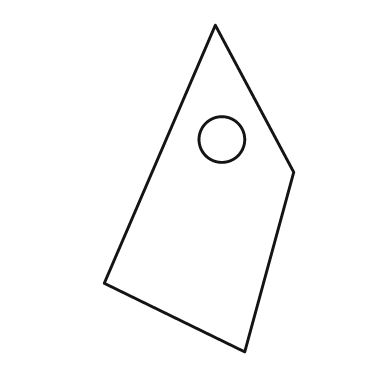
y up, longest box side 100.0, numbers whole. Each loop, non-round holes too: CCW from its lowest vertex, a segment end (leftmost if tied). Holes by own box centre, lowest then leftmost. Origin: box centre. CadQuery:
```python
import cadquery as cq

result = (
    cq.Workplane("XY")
    .moveTo(14.0, -50.0)
    .lineTo(29.0, 5.0)
    .lineTo(5.0, 50.0)
    .lineTo(-29.0, -29.0)
    .close()
    .moveTo(7.0, 15.0)
    .circle(7.0)
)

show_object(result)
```